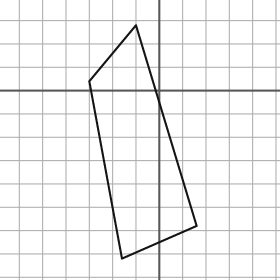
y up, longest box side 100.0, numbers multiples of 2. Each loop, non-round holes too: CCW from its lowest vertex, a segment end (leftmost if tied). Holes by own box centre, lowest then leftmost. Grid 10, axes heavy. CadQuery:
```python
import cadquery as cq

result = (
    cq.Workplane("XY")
    .moveTo(-16.0, -72.0)
    .lineTo(16.0, -58.0)
    .lineTo(-10.0, 28.0)
    .lineTo(-30.0, 4.0)
    .close()
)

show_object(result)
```